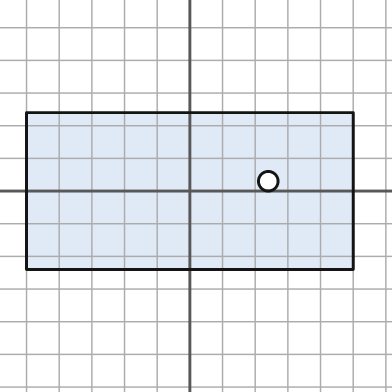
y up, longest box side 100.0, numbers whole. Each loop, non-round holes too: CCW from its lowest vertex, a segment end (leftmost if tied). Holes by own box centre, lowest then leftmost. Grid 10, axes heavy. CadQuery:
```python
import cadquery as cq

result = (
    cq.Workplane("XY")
    .moveTo(-50.0, -24.0)
    .lineTo(50.0, -24.0)
    .lineTo(50.0, 24.0)
    .lineTo(-50.0, 24.0)
    .close()
    .moveTo(24.0, 3.0)
    .circle(3.0)
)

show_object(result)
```